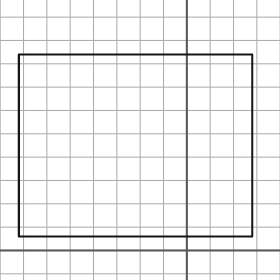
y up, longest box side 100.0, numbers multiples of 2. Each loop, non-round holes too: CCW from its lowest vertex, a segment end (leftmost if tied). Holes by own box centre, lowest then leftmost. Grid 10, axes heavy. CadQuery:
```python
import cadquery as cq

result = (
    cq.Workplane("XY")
    .moveTo(-72.0, 6.0)
    .lineTo(28.0, 6.0)
    .lineTo(28.0, 84.0)
    .lineTo(-72.0, 84.0)
    .close()
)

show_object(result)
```